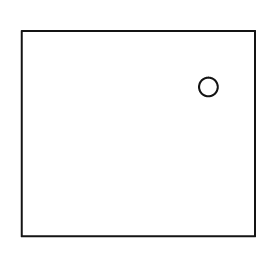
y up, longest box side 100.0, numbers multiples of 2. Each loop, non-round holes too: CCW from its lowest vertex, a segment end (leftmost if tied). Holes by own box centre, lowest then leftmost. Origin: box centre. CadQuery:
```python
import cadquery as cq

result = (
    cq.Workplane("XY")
    .moveTo(-50.0, -44.0)
    .lineTo(50.0, -44.0)
    .lineTo(50.0, 44.0)
    .lineTo(-50.0, 44.0)
    .close()
    .moveTo(30.0, 20.0)
    .circle(4.0)
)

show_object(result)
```